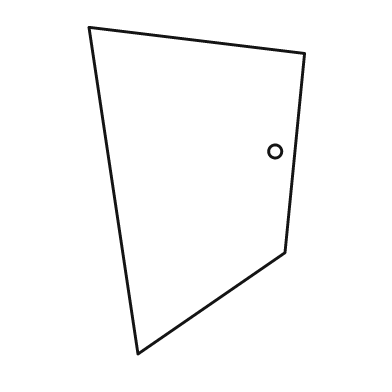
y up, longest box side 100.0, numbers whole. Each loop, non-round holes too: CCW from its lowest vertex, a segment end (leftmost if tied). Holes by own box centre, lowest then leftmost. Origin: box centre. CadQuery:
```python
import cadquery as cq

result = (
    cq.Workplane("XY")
    .moveTo(-18.0, -50.0)
    .lineTo(27.0, -19.0)
    .lineTo(33.0, 42.0)
    .lineTo(-33.0, 50.0)
    .close()
    .moveTo(24.0, 12.0)
    .circle(2.0)
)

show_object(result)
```